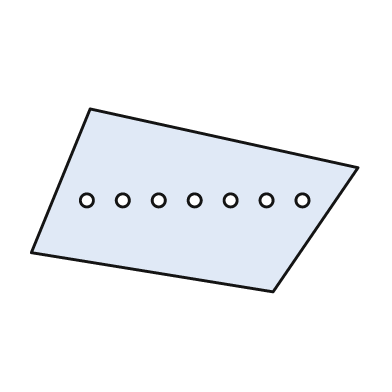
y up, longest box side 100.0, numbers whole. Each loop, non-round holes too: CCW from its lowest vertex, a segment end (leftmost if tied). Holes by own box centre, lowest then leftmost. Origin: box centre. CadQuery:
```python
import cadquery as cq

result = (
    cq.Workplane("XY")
    .moveTo(24.0, -28.0)
    .lineTo(50.0, 10.0)
    .lineTo(-32.0, 28.0)
    .lineTo(-50.0, -16.0)
    .close()
    .moveTo(-33.0, 0.0)
    .circle(2.0)
    .moveTo(-22.0, 0.0)
    .circle(2.0)
    .moveTo(-11.0, 0.0)
    .circle(2.0)
    .moveTo(0.0, 0.0)
    .circle(2.0)
    .moveTo(11.0, 0.0)
    .circle(2.0)
    .moveTo(22.0, 0.0)
    .circle(2.0)
    .moveTo(33.0, 0.0)
    .circle(2.0)
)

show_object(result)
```